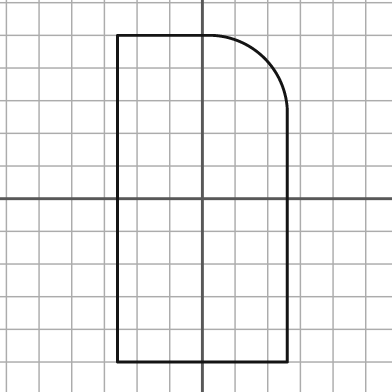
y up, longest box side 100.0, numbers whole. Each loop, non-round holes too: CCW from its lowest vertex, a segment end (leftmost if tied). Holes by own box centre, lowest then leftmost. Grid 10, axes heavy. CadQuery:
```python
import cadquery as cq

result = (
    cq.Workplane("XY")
    .moveTo(-26.0, -50.0)
    .lineTo(26.0, -50.0)
    .lineTo(26.0, 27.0)
    .threePointArc((19.0, 43.0), (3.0, 50.0))
    .lineTo(-26.0, 50.0)
    .close()
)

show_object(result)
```